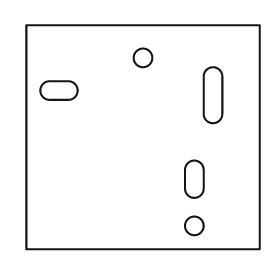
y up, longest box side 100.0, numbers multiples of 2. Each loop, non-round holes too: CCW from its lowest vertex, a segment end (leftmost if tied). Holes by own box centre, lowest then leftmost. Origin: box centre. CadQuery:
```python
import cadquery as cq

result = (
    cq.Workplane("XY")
    .moveTo(-50.0, -48.0)
    .lineTo(50.0, -48.0)
    .lineTo(50.0, 48.0)
    .lineTo(-50.0, 48.0)
    .close()
    .moveTo(22.0, -38.0)
    .circle(4.0)
    .moveTo(18.0, -22.0)
    .threePointArc((22.0, -26.0), (26.0, -22.0))
    .lineTo(26.0, -14.0)
    .threePointArc((22.0, -10.0), (18.0, -14.0))
    .close()
    .moveTo(26.0, 10.0)
    .threePointArc((30.0, 6.0), (34.0, 10.0))
    .lineTo(34.0, 26.0)
    .threePointArc((30.0, 30.0), (26.0, 26.0))
    .close()
    .moveTo(-40.0, 16.0)
    .lineTo(-32.0, 16.0)
    .threePointArc((-28.0, 20.0), (-32.0, 24.0))
    .lineTo(-40.0, 24.0)
    .threePointArc((-44.0, 20.0), (-40.0, 16.0))
    .close()
    .moveTo(0.0, 34.0)
    .circle(4.0)
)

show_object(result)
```